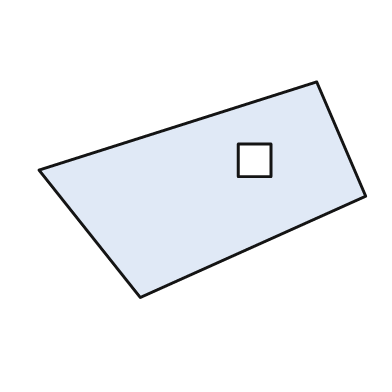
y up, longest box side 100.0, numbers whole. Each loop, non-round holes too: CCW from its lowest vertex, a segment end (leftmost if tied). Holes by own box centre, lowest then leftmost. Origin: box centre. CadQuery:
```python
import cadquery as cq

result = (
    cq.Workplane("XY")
    .moveTo(-19.0, -33.0)
    .lineTo(50.0, -2.0)
    .lineTo(35.0, 33.0)
    .lineTo(-50.0, 6.0)
    .close()
    .moveTo(11.0, 4.0)
    .lineTo(21.0, 4.0)
    .lineTo(21.0, 14.0)
    .lineTo(11.0, 14.0)
    .close()
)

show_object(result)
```